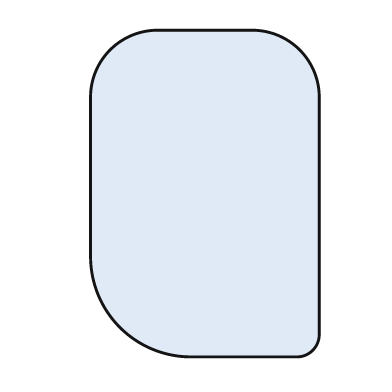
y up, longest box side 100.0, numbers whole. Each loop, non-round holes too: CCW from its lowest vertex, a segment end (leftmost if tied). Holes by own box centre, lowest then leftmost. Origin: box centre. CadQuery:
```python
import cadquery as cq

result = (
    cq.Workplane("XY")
    .moveTo(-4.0, -50.0)
    .lineTo(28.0, -50.0)
    .threePointArc((33.0, -48.0), (35.0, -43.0))
    .lineTo(35.0, 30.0)
    .threePointArc((29.0, 44.0), (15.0, 50.0))
    .lineTo(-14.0, 50.0)
    .threePointArc((-29.0, 44.0), (-35.0, 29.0))
    .lineTo(-35.0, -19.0)
    .threePointArc((-26.0, -41.0), (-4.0, -50.0))
    .close()
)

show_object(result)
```